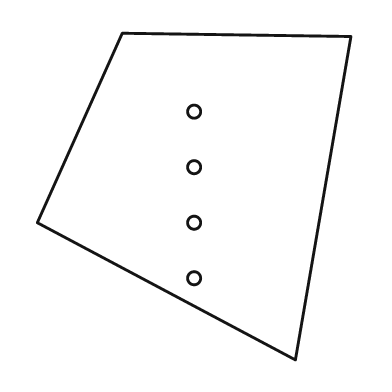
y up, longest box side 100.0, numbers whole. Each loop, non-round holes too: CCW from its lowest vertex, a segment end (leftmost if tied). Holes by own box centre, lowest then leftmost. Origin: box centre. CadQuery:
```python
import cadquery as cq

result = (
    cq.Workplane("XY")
    .moveTo(31.0, -50.0)
    .lineTo(48.0, 49.0)
    .lineTo(-22.0, 50.0)
    .lineTo(-48.0, -8.0)
    .close()
    .moveTo(0.0, -25.0)
    .circle(2.0)
    .moveTo(0.0, -8.0)
    .circle(2.0)
    .moveTo(0.0, 9.0)
    .circle(2.0)
    .moveTo(0.0, 26.0)
    .circle(2.0)
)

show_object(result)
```